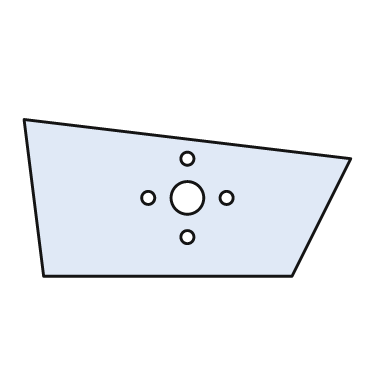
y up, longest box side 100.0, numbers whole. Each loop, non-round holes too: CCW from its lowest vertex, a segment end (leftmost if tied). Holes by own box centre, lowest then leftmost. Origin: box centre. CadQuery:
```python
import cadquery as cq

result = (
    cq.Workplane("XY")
    .moveTo(-44.0, -24.0)
    .lineTo(32.0, -24.0)
    .lineTo(50.0, 12.0)
    .lineTo(-50.0, 24.0)
    .close()
    .moveTo(0.0, -12.0)
    .circle(2.0)
    .moveTo(-12.0, 0.0)
    .circle(2.0)
    .moveTo(0.0, 0.0)
    .circle(5.0)
    .moveTo(12.0, 0.0)
    .circle(2.0)
    .moveTo(0.0, 12.0)
    .circle(2.0)
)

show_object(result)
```